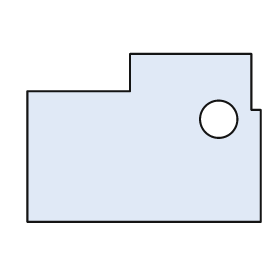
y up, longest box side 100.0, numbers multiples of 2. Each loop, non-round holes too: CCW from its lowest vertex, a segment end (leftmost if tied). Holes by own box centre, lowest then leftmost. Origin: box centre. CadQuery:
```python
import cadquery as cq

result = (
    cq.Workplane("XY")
    .moveTo(-50.0, -36.0)
    .lineTo(50.0, -36.0)
    .lineTo(50.0, 12.0)
    .lineTo(46.0, 12.0)
    .lineTo(46.0, 36.0)
    .lineTo(-6.0, 36.0)
    .lineTo(-6.0, 20.0)
    .lineTo(-50.0, 20.0)
    .close()
    .moveTo(32.0, 8.0)
    .circle(8.0)
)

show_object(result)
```